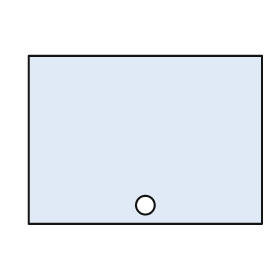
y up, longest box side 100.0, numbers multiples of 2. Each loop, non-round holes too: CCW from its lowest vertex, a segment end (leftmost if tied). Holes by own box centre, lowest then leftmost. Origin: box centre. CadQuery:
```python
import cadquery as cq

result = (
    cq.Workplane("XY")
    .moveTo(-50.0, -36.0)
    .lineTo(50.0, -36.0)
    .lineTo(50.0, 36.0)
    .lineTo(-50.0, 36.0)
    .close()
    .moveTo(0.0, -28.0)
    .circle(4.0)
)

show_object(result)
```